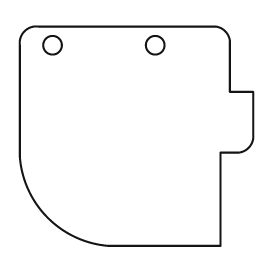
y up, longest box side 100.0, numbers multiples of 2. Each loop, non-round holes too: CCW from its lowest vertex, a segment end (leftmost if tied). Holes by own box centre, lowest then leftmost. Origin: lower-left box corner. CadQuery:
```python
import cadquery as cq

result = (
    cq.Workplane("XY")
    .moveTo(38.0, 0.0)
    .lineTo(86.0, 0.0)
    .lineTo(86.0, 40.0)
    .lineTo(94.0, 40.0)
    .threePointArc((98.0, 42.0), (100.0, 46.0))
    .lineTo(100.0, 66.0)
    .lineTo(90.0, 66.0)
    .lineTo(90.0, 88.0)
    .threePointArc((88.0, 92.0), (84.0, 94.0))
    .lineTo(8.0, 94.0)
    .threePointArc((2.0, 92.0), (0.0, 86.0))
    .lineTo(0.0, 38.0)
    .threePointArc((12.0, 12.0), (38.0, 0.0))
    .close()
    .moveTo(14.0, 86.0)
    .circle(4.0)
    .moveTo(58.0, 86.0)
    .circle(4.0)
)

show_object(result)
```